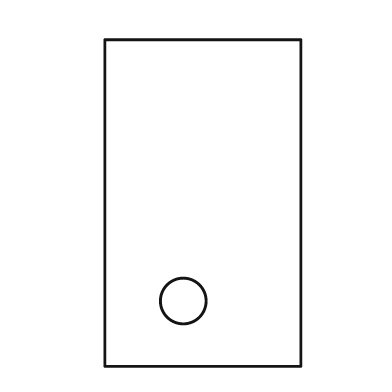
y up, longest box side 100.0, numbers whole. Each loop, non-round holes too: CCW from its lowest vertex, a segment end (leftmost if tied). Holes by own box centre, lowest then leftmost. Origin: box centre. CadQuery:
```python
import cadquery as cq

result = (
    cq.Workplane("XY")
    .moveTo(-30.0, -50.0)
    .lineTo(30.0, -50.0)
    .lineTo(30.0, 50.0)
    .lineTo(-30.0, 50.0)
    .close()
    .moveTo(-6.0, -30.0)
    .circle(7.0)
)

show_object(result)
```